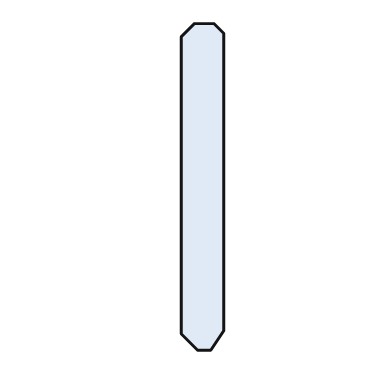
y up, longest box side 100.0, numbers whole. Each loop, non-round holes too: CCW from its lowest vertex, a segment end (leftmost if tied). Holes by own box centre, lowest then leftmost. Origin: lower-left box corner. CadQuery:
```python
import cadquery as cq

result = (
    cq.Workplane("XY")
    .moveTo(5.0, 0.0)
    .lineTo(9.0, 0.0)
    .lineTo(13.0, 6.0)
    .lineTo(13.0, 97.0)
    .lineTo(10.0, 100.0)
    .lineTo(4.0, 100.0)
    .lineTo(0.0, 96.0)
    .lineTo(0.0, 5.0)
    .close()
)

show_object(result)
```